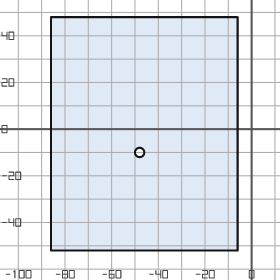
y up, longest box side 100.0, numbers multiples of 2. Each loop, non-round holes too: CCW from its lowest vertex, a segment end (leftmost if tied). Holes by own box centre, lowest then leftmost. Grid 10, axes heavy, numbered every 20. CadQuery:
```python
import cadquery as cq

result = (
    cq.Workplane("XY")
    .moveTo(-86.0, -52.0)
    .lineTo(-6.0, -52.0)
    .lineTo(-6.0, 48.0)
    .lineTo(-86.0, 48.0)
    .close()
    .moveTo(-48.0, -10.0)
    .circle(2.0)
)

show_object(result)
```